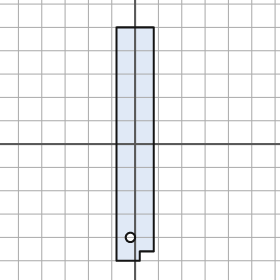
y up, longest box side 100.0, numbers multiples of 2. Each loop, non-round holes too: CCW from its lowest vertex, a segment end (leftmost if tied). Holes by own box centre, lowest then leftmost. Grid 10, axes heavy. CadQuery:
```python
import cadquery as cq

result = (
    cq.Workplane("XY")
    .moveTo(-8.0, -50.0)
    .lineTo(2.0, -50.0)
    .lineTo(2.0, -46.0)
    .lineTo(8.0, -46.0)
    .lineTo(8.0, 50.0)
    .lineTo(-8.0, 50.0)
    .close()
    .moveTo(-2.0, -40.0)
    .circle(2.0)
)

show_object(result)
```